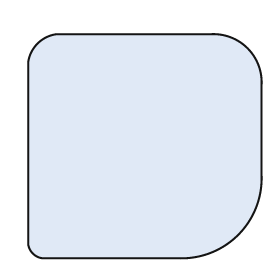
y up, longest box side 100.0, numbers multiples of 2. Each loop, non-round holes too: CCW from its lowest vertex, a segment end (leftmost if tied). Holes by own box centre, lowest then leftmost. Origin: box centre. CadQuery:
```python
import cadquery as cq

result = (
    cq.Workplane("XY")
    .moveTo(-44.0, -48.0)
    .lineTo(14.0, -48.0)
    .threePointArc((40.0, -38.0), (50.0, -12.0))
    .lineTo(50.0, 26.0)
    .threePointArc((44.0, 42.0), (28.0, 48.0))
    .lineTo(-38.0, 48.0)
    .threePointArc((-46.0, 44.0), (-50.0, 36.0))
    .lineTo(-50.0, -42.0)
    .threePointArc((-48.0, -46.0), (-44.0, -48.0))
    .close()
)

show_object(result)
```